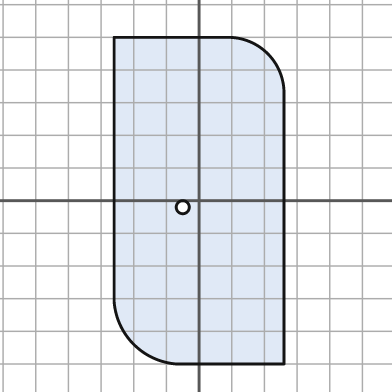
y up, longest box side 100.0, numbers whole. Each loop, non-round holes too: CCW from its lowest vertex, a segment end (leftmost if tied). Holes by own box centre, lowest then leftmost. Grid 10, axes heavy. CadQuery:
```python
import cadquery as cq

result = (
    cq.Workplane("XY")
    .moveTo(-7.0, -50.0)
    .lineTo(26.0, -50.0)
    .lineTo(26.0, 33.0)
    .threePointArc((21.0, 45.0), (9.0, 50.0))
    .lineTo(-26.0, 50.0)
    .lineTo(-26.0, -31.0)
    .threePointArc((-20.0, -44.0), (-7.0, -50.0))
    .close()
    .moveTo(-5.0, -2.0)
    .circle(2.0)
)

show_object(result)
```